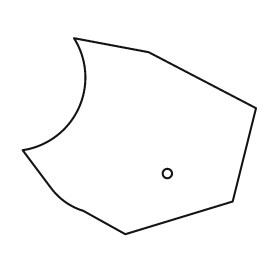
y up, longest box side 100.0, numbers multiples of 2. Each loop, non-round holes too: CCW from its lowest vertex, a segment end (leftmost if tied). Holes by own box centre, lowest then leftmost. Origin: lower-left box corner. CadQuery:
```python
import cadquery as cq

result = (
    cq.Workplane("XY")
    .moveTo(44.0, 0.0)
    .lineTo(90.0, 14.0)
    .lineTo(100.0, 54.0)
    .lineTo(54.0, 78.0)
    .lineTo(22.0, 84.0)
    .threePointArc((24.0, 54.0), (0.0, 36.0))
    .lineTo(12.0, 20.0)
    .threePointArc((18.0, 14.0), (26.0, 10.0))
    .close()
    .moveTo(62.0, 26.0)
    .circle(2.0)
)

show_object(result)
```